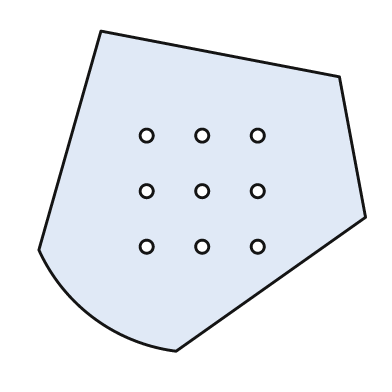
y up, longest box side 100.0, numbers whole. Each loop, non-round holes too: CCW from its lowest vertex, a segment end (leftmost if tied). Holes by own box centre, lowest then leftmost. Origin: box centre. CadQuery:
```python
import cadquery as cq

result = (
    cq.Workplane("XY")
    .moveTo(-8.0, -49.0)
    .lineTo(50.0, -8.0)
    .lineTo(42.0, 35.0)
    .lineTo(-31.0, 49.0)
    .lineTo(-50.0, -18.0)
    .threePointArc((-33.0, -39.0), (-8.0, -49.0))
    .close()
    .moveTo(-17.0, -17.0)
    .circle(2.0)
    .moveTo(0.0, -17.0)
    .circle(2.0)
    .moveTo(17.0, -17.0)
    .circle(2.0)
    .moveTo(-17.0, 0.0)
    .circle(2.0)
    .moveTo(0.0, 0.0)
    .circle(2.0)
    .moveTo(17.0, 0.0)
    .circle(2.0)
    .moveTo(-17.0, 17.0)
    .circle(2.0)
    .moveTo(0.0, 17.0)
    .circle(2.0)
    .moveTo(17.0, 17.0)
    .circle(2.0)
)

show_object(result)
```